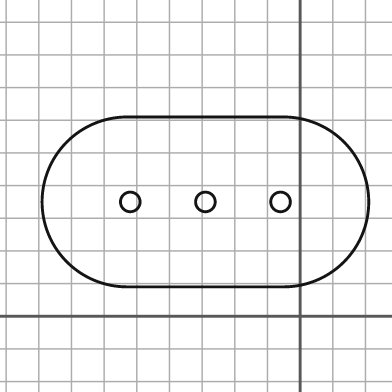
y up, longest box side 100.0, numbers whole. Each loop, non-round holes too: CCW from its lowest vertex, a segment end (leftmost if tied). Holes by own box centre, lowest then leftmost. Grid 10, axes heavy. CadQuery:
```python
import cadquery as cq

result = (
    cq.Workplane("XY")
    .moveTo(-53.0, 9.0)
    .lineTo(-5.0, 9.0)
    .threePointArc((21.0, 35.0), (-5.0, 61.0))
    .lineTo(-53.0, 61.0)
    .threePointArc((-79.0, 35.0), (-53.0, 9.0))
    .close()
    .moveTo(-52.0, 35.0)
    .circle(3.0)
    .moveTo(-29.0, 35.0)
    .circle(3.0)
    .moveTo(-6.0, 35.0)
    .circle(3.0)
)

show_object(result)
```